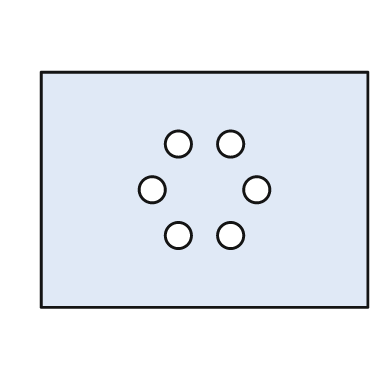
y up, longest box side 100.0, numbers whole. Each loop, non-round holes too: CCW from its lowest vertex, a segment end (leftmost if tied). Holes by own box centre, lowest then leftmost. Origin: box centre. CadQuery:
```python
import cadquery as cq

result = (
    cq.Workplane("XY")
    .moveTo(-50.0, -36.0)
    .lineTo(50.0, -36.0)
    .lineTo(50.0, 36.0)
    .lineTo(-50.0, 36.0)
    .close()
    .moveTo(-8.0, -14.0)
    .circle(4.0)
    .moveTo(8.0, -14.0)
    .circle(4.0)
    .moveTo(-16.0, 0.0)
    .circle(4.0)
    .moveTo(16.0, 0.0)
    .circle(4.0)
    .moveTo(-8.0, 14.0)
    .circle(4.0)
    .moveTo(8.0, 14.0)
    .circle(4.0)
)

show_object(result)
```